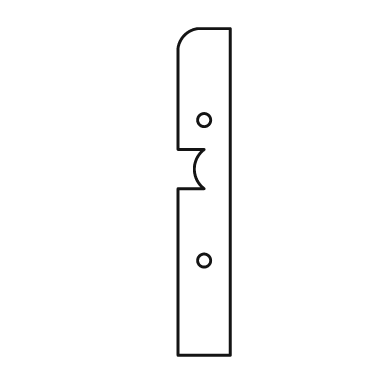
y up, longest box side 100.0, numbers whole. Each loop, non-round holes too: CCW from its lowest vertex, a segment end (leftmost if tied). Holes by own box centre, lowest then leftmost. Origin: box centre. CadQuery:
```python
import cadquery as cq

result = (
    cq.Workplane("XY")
    .moveTo(-8.0, -50.0)
    .lineTo(8.0, -50.0)
    .lineTo(8.0, 50.0)
    .lineTo(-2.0, 50.0)
    .threePointArc((-6.0, 48.0), (-8.0, 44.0))
    .lineTo(-8.0, 13.0)
    .lineTo(0.0, 13.0)
    .threePointArc((-3.0, 7.0), (0.0, 1.0))
    .lineTo(-8.0, 1.0)
    .close()
    .moveTo(0.0, -21.0)
    .circle(2.0)
    .moveTo(0.0, 22.0)
    .circle(2.0)
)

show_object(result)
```